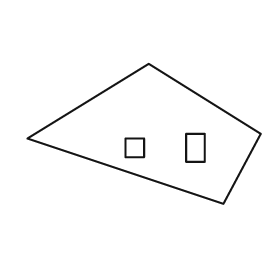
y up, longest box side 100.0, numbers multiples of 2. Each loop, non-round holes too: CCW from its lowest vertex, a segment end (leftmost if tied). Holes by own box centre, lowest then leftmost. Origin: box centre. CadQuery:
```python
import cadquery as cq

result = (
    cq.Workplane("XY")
    .moveTo(34.0, -30.0)
    .lineTo(50.0, 0.0)
    .lineTo(2.0, 30.0)
    .lineTo(-50.0, -2.0)
    .close()
    .moveTo(-8.0, -10.0)
    .lineTo(0.0, -10.0)
    .lineTo(0.0, -2.0)
    .lineTo(-8.0, -2.0)
    .close()
    .moveTo(18.0, -12.0)
    .lineTo(26.0, -12.0)
    .lineTo(26.0, 0.0)
    .lineTo(18.0, 0.0)
    .close()
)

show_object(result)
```